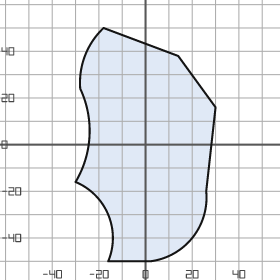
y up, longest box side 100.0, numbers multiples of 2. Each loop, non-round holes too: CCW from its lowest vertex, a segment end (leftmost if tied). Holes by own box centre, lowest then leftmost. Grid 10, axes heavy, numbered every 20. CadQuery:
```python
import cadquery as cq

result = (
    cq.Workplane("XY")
    .moveTo(-16.0, -50.0)
    .lineTo(2.0, -50.0)
    .threePointArc((20.0, -40.0), (26.0, -20.0))
    .lineTo(30.0, 16.0)
    .lineTo(14.0, 38.0)
    .lineTo(-18.0, 50.0)
    .threePointArc((-26.0, 38.0), (-28.0, 24.0))
    .threePointArc((-24.0, 4.0), (-30.0, -16.0))
    .threePointArc((-16.0, -30.0), (-16.0, -50.0))
    .close()
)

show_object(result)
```